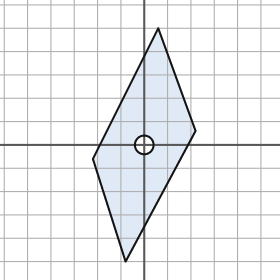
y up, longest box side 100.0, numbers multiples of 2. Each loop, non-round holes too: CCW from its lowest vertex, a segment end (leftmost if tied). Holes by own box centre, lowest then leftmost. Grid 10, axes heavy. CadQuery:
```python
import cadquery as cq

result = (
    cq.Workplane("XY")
    .moveTo(-8.0, -50.0)
    .lineTo(22.0, 6.0)
    .lineTo(6.0, 50.0)
    .lineTo(-22.0, -6.0)
    .close()
    .moveTo(0.0, 0.0)
    .circle(4.0)
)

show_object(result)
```